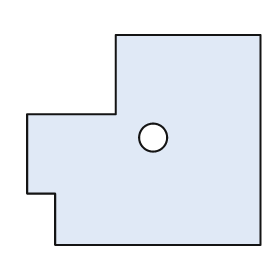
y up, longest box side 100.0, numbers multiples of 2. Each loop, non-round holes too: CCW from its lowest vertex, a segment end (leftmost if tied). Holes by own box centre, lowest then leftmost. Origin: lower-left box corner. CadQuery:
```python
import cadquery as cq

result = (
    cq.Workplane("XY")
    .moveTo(12.0, 0.0)
    .lineTo(100.0, 0.0)
    .lineTo(100.0, 90.0)
    .lineTo(38.0, 90.0)
    .lineTo(38.0, 56.0)
    .lineTo(0.0, 56.0)
    .lineTo(0.0, 22.0)
    .lineTo(12.0, 22.0)
    .close()
    .moveTo(54.0, 46.0)
    .circle(6.0)
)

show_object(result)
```